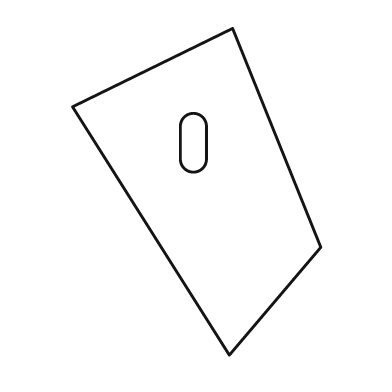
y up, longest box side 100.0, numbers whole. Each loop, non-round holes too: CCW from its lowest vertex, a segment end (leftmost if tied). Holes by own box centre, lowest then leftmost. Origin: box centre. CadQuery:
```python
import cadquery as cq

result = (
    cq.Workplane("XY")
    .moveTo(10.0, -50.0)
    .lineTo(38.0, -17.0)
    .lineTo(11.0, 50.0)
    .lineTo(-38.0, 26.0)
    .close()
    .moveTo(-5.0, 10.0)
    .threePointArc((-1.0, 6.0), (3.0, 10.0))
    .lineTo(3.0, 20.0)
    .threePointArc((-1.0, 24.0), (-5.0, 20.0))
    .close()
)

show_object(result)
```